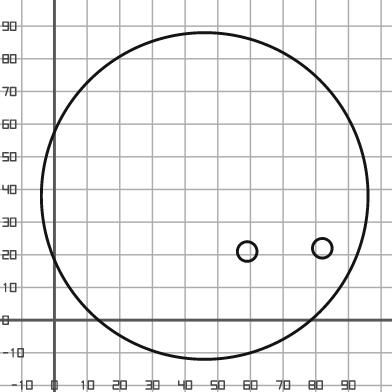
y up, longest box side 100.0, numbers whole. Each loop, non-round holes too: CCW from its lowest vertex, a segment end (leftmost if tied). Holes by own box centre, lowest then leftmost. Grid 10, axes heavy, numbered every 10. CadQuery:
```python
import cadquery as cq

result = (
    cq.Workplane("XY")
    .moveTo(46.0, 38.0)
    .circle(50.0)
    .moveTo(59.0, 21.0)
    .circle(3.0)
    .moveTo(82.0, 22.0)
    .circle(3.0)
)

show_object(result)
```